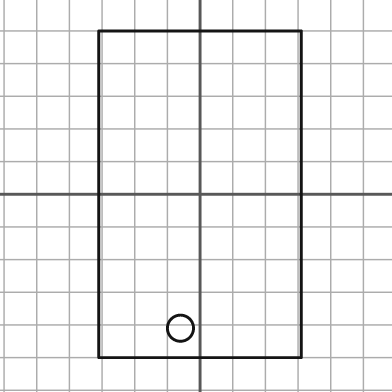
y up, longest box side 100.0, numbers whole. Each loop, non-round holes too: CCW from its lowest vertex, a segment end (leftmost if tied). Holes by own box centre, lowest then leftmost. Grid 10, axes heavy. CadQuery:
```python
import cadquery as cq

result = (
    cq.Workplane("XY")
    .moveTo(-31.0, -50.0)
    .lineTo(31.0, -50.0)
    .lineTo(31.0, 50.0)
    .lineTo(-31.0, 50.0)
    .close()
    .moveTo(-6.0, -41.0)
    .circle(4.0)
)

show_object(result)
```